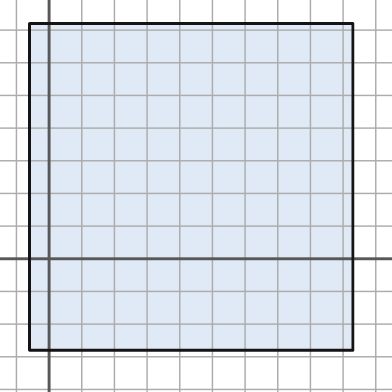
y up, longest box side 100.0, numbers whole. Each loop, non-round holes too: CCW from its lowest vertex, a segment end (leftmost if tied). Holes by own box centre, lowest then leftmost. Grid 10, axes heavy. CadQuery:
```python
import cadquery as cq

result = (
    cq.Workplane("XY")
    .moveTo(-6.0, -28.0)
    .lineTo(93.0, -28.0)
    .lineTo(93.0, 72.0)
    .lineTo(-6.0, 72.0)
    .close()
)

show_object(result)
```